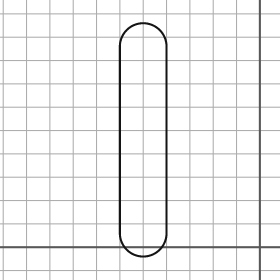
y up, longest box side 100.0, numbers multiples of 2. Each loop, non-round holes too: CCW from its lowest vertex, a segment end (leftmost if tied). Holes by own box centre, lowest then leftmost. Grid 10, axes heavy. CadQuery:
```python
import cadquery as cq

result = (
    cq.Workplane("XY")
    .moveTo(-60.0, 6.0)
    .threePointArc((-50.0, -4.0), (-40.0, 6.0))
    .lineTo(-40.0, 86.0)
    .threePointArc((-50.0, 96.0), (-60.0, 86.0))
    .close()
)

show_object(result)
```